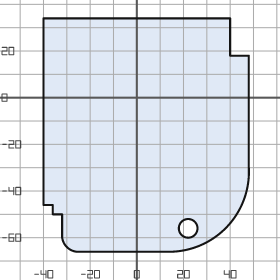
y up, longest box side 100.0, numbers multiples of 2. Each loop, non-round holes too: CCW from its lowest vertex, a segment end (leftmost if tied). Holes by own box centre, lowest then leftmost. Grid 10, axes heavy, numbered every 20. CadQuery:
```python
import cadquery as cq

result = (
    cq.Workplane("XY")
    .moveTo(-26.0, -66.0)
    .lineTo(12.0, -66.0)
    .threePointArc((38.0, -56.0), (48.0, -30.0))
    .lineTo(48.0, 18.0)
    .lineTo(40.0, 18.0)
    .lineTo(40.0, 34.0)
    .lineTo(-40.0, 34.0)
    .lineTo(-40.0, -46.0)
    .lineTo(-36.0, -46.0)
    .lineTo(-36.0, -50.0)
    .lineTo(-32.0, -50.0)
    .lineTo(-32.0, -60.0)
    .threePointArc((-30.0, -64.0), (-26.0, -66.0))
    .close()
    .moveTo(22.0, -56.0)
    .circle(4.0)
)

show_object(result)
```